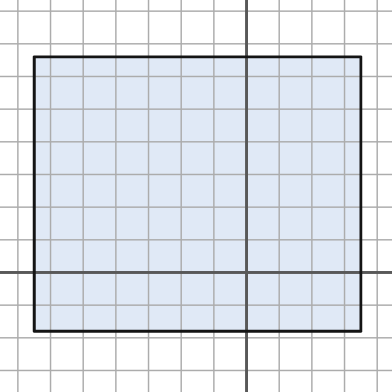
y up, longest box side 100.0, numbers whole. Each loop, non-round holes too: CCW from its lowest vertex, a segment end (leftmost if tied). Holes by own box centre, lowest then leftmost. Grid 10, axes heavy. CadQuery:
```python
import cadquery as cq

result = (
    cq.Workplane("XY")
    .moveTo(-65.0, -18.0)
    .lineTo(35.0, -18.0)
    .lineTo(35.0, 66.0)
    .lineTo(-65.0, 66.0)
    .close()
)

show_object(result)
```